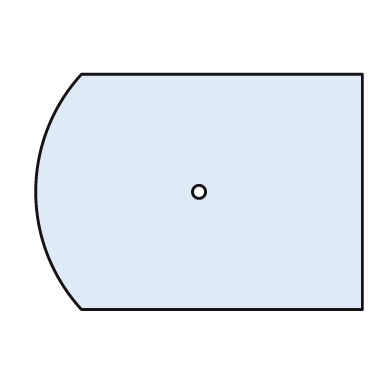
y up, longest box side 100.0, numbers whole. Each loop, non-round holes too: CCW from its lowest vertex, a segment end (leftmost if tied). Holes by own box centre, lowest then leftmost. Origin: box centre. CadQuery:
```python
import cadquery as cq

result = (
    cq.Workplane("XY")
    .moveTo(-36.0, -36.0)
    .lineTo(50.0, -36.0)
    .lineTo(50.0, 36.0)
    .lineTo(-36.0, 36.0)
    .threePointArc((-50.0, 0.0), (-36.0, -36.0))
    .close()
    .moveTo(0.0, 0.0)
    .circle(2.0)
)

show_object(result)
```